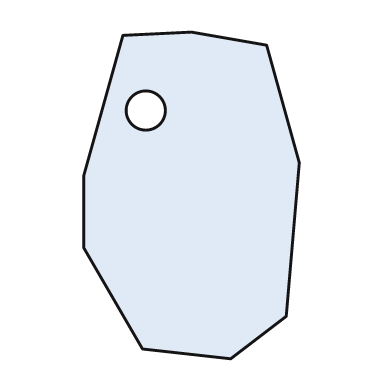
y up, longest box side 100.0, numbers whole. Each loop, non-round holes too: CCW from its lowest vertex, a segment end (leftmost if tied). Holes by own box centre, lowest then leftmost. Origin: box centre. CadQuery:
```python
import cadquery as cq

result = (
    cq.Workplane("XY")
    .moveTo(12.0, -50.0)
    .lineTo(29.0, -37.0)
    .lineTo(33.0, 10.0)
    .lineTo(23.0, 46.0)
    .lineTo(0.0, 50.0)
    .lineTo(-21.0, 49.0)
    .lineTo(-33.0, 6.0)
    .lineTo(-33.0, -16.0)
    .lineTo(-15.0, -47.0)
    .close()
    .moveTo(-14.0, 26.0)
    .circle(6.0)
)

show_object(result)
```